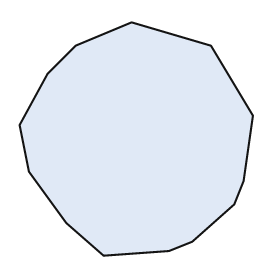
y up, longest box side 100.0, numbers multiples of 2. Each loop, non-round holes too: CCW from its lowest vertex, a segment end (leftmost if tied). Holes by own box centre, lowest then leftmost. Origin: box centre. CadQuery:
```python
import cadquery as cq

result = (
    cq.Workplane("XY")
    .moveTo(-14.0, -50.0)
    .lineTo(14.0, -48.0)
    .lineTo(24.0, -44.0)
    .lineTo(42.0, -28.0)
    .lineTo(46.0, -18.0)
    .lineTo(50.0, 10.0)
    .lineTo(32.0, 40.0)
    .lineTo(-2.0, 50.0)
    .lineTo(-26.0, 40.0)
    .lineTo(-38.0, 28.0)
    .lineTo(-50.0, 6.0)
    .lineTo(-46.0, -14.0)
    .lineTo(-30.0, -36.0)
    .close()
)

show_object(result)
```